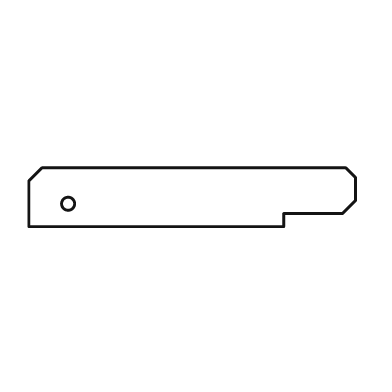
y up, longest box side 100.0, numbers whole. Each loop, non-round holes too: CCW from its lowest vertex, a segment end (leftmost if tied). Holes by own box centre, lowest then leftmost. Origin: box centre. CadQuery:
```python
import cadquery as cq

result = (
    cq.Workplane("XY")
    .moveTo(-50.0, -9.0)
    .lineTo(28.0, -9.0)
    .lineTo(28.0, -5.0)
    .lineTo(46.0, -5.0)
    .lineTo(50.0, -1.0)
    .lineTo(50.0, 6.0)
    .lineTo(47.0, 9.0)
    .lineTo(-46.0, 9.0)
    .lineTo(-50.0, 5.0)
    .close()
    .moveTo(-38.0, -2.0)
    .circle(2.0)
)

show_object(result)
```